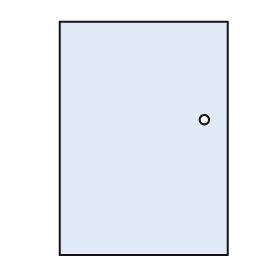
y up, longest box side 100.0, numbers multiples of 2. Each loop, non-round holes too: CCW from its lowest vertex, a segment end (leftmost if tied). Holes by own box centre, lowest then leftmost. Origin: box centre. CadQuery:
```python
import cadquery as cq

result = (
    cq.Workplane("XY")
    .moveTo(-36.0, -50.0)
    .lineTo(36.0, -50.0)
    .lineTo(36.0, 50.0)
    .lineTo(-36.0, 50.0)
    .close()
    .moveTo(26.0, 8.0)
    .circle(2.0)
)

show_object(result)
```